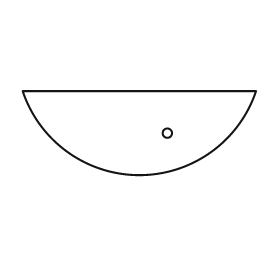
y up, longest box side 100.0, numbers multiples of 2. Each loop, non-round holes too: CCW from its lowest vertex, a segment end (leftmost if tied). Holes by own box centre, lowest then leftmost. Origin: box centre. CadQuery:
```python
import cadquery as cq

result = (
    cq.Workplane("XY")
    .moveTo(-50.0, 18.0)
    .threePointArc((0.0, -18.0), (50.0, 18.0))
    .close()
    .moveTo(12.0, 0.0)
    .circle(2.0)
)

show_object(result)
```